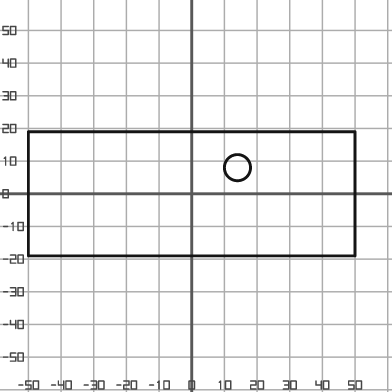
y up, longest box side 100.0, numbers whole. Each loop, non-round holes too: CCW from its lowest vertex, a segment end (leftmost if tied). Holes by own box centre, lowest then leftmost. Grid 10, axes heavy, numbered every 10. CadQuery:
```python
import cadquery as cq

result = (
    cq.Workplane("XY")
    .moveTo(-50.0, -19.0)
    .lineTo(50.0, -19.0)
    .lineTo(50.0, 19.0)
    .lineTo(-50.0, 19.0)
    .close()
    .moveTo(14.0, 8.0)
    .circle(4.0)
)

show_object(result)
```